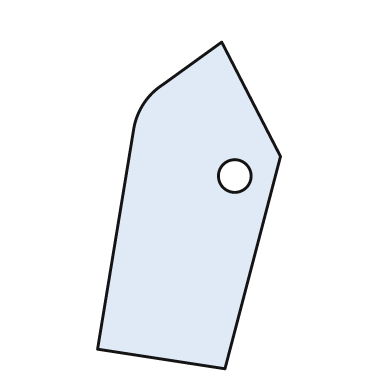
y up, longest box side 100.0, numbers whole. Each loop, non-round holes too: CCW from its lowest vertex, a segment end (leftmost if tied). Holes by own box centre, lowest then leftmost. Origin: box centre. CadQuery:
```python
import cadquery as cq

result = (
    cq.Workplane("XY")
    .moveTo(11.0, -50.0)
    .lineTo(28.0, 15.0)
    .lineTo(10.0, 50.0)
    .lineTo(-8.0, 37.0)
    .threePointArc((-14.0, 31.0), (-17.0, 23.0))
    .lineTo(-28.0, -44.0)
    .close()
    .moveTo(14.0, 9.0)
    .circle(5.0)
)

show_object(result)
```